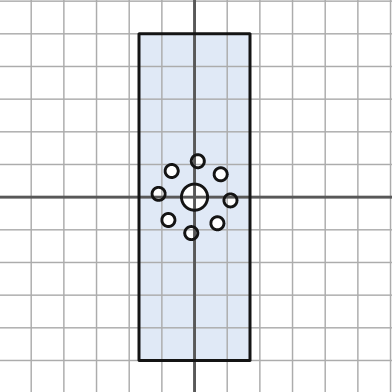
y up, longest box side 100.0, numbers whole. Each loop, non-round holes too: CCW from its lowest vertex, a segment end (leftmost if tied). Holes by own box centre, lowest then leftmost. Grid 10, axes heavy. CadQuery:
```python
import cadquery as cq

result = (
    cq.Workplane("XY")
    .moveTo(-17.0, -50.0)
    .lineTo(17.0, -50.0)
    .lineTo(17.0, 50.0)
    .lineTo(-17.0, 50.0)
    .close()
    .moveTo(-1.0, -11.0)
    .circle(2.0)
    .moveTo(7.0, -8.0)
    .circle(2.0)
    .moveTo(-8.0, -7.0)
    .circle(2.0)
    .moveTo(11.0, -1.0)
    .circle(2.0)
    .moveTo(0.0, 0.0)
    .circle(4.0)
    .moveTo(-11.0, 1.0)
    .circle(2.0)
    .moveTo(8.0, 7.0)
    .circle(2.0)
    .moveTo(-7.0, 8.0)
    .circle(2.0)
    .moveTo(1.0, 11.0)
    .circle(2.0)
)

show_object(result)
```